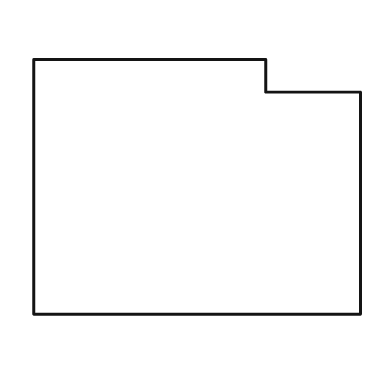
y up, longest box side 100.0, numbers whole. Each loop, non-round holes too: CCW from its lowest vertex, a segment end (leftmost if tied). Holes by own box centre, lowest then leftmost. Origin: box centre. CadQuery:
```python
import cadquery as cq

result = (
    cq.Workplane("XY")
    .moveTo(-50.0, -39.0)
    .lineTo(50.0, -39.0)
    .lineTo(50.0, 29.0)
    .lineTo(21.0, 29.0)
    .lineTo(21.0, 39.0)
    .lineTo(-50.0, 39.0)
    .close()
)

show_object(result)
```